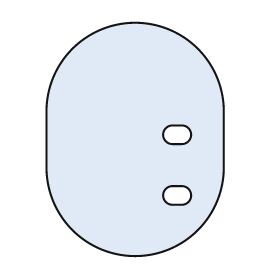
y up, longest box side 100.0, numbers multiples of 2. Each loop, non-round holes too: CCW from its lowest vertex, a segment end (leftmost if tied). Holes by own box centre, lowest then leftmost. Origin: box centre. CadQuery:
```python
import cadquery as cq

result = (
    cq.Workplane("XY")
    .moveTo(-38.0, -12.0)
    .threePointArc((0.0, -50.0), (38.0, -12.0))
    .lineTo(38.0, 12.0)
    .threePointArc((0.0, 50.0), (-38.0, 12.0))
    .close()
    .moveTo(16.0, -28.0)
    .lineTo(20.0, -28.0)
    .threePointArc((24.0, -24.0), (20.0, -20.0))
    .lineTo(16.0, -20.0)
    .threePointArc((12.0, -24.0), (16.0, -28.0))
    .close()
    .moveTo(16.0, -2.0)
    .lineTo(20.0, -2.0)
    .threePointArc((24.0, 2.0), (20.0, 6.0))
    .lineTo(16.0, 6.0)
    .threePointArc((12.0, 2.0), (16.0, -2.0))
    .close()
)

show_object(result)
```